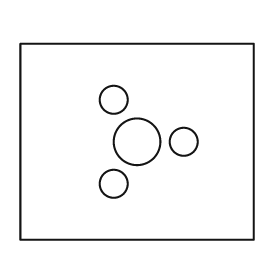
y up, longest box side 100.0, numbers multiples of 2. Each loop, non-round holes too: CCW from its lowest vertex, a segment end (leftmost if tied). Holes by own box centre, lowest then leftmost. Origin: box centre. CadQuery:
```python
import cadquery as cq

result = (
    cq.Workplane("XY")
    .moveTo(-50.0, -42.0)
    .lineTo(50.0, -42.0)
    .lineTo(50.0, 42.0)
    .lineTo(-50.0, 42.0)
    .close()
    .moveTo(-10.0, -18.0)
    .circle(6.0)
    .moveTo(0.0, 0.0)
    .circle(10.0)
    .moveTo(20.0, 0.0)
    .circle(6.0)
    .moveTo(-10.0, 18.0)
    .circle(6.0)
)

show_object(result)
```